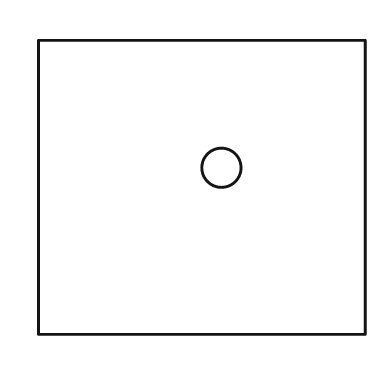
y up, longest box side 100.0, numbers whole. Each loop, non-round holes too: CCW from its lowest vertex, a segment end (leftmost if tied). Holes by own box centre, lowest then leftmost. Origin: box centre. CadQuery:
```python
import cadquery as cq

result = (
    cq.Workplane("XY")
    .moveTo(-50.0, -45.0)
    .lineTo(50.0, -45.0)
    .lineTo(50.0, 45.0)
    .lineTo(-50.0, 45.0)
    .close()
    .moveTo(6.0, 6.0)
    .circle(6.0)
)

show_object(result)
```